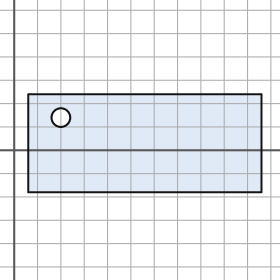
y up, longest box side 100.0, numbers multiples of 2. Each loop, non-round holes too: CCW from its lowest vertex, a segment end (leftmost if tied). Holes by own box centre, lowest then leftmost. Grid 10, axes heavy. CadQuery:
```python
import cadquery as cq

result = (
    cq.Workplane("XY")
    .moveTo(6.0, -18.0)
    .lineTo(106.0, -18.0)
    .lineTo(106.0, 24.0)
    .lineTo(6.0, 24.0)
    .close()
    .moveTo(20.0, 14.0)
    .circle(4.0)
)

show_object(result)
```